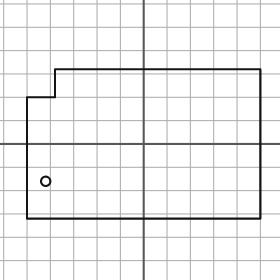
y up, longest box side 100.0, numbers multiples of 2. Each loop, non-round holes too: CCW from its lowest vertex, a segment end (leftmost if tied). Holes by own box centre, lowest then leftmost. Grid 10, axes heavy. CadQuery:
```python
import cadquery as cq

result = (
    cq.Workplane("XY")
    .moveTo(-50.0, -32.0)
    .lineTo(50.0, -32.0)
    .lineTo(50.0, 32.0)
    .lineTo(-38.0, 32.0)
    .lineTo(-38.0, 20.0)
    .lineTo(-50.0, 20.0)
    .close()
    .moveTo(-42.0, -16.0)
    .circle(2.0)
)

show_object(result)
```